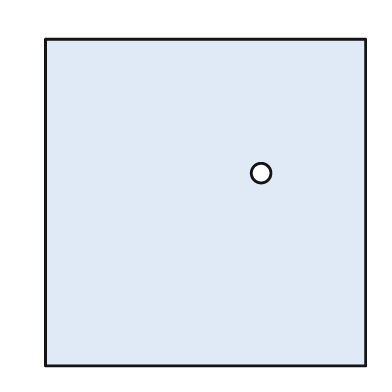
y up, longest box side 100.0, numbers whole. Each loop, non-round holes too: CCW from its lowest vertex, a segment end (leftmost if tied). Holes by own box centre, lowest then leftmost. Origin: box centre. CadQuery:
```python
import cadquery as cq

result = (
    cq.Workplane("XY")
    .moveTo(-49.0, -50.0)
    .lineTo(49.0, -50.0)
    .lineTo(49.0, 50.0)
    .lineTo(-49.0, 50.0)
    .close()
    .moveTo(17.0, 9.0)
    .circle(3.0)
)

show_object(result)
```